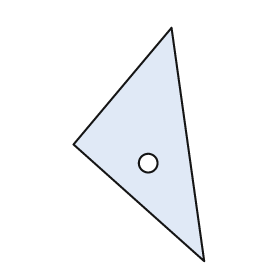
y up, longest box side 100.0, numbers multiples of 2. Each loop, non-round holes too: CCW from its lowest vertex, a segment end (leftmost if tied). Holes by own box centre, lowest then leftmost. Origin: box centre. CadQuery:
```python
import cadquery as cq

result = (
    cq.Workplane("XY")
    .moveTo(28.0, -50.0)
    .lineTo(14.0, 50.0)
    .lineTo(-28.0, 0.0)
    .close()
    .moveTo(4.0, -8.0)
    .circle(4.0)
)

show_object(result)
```